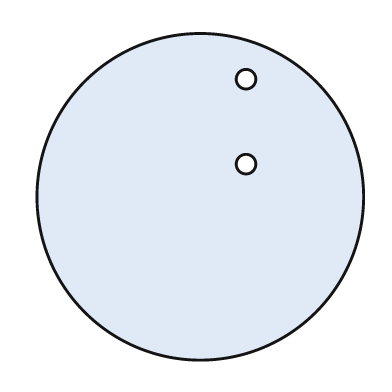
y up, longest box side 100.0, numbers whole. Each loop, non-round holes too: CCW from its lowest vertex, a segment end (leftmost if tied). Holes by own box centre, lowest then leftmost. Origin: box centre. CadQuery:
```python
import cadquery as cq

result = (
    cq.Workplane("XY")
    .moveTo(0.0, 0.0)
    .circle(50.0)
    .moveTo(14.0, 10.0)
    .circle(3.0)
    .moveTo(14.0, 36.0)
    .circle(3.0)
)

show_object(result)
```